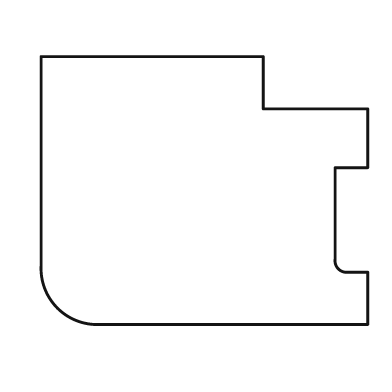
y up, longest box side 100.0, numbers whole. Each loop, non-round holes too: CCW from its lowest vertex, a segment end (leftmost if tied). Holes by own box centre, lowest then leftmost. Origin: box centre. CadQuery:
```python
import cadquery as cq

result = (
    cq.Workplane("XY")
    .moveTo(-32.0, -41.0)
    .lineTo(50.0, -41.0)
    .lineTo(50.0, -25.0)
    .lineTo(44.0, -25.0)
    .threePointArc((41.0, -24.0), (40.0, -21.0))
    .lineTo(40.0, 7.0)
    .lineTo(50.0, 7.0)
    .lineTo(50.0, 25.0)
    .lineTo(18.0, 25.0)
    .lineTo(18.0, 41.0)
    .lineTo(-50.0, 41.0)
    .lineTo(-50.0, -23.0)
    .threePointArc((-45.0, -36.0), (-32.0, -41.0))
    .close()
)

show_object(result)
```